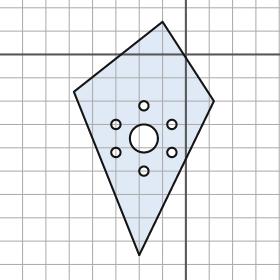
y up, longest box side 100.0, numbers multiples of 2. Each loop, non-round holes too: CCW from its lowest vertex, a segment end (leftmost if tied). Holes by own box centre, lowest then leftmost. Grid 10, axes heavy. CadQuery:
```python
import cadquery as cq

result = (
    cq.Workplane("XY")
    .moveTo(-20.0, -86.0)
    .lineTo(12.0, -20.0)
    .lineTo(-10.0, 14.0)
    .lineTo(-48.0, -16.0)
    .close()
    .moveTo(-18.0, -50.0)
    .circle(2.0)
    .moveTo(-30.0, -42.0)
    .circle(2.0)
    .moveTo(-6.0, -42.0)
    .circle(2.0)
    .moveTo(-18.0, -36.0)
    .circle(6.0)
    .moveTo(-30.0, -30.0)
    .circle(2.0)
    .moveTo(-6.0, -30.0)
    .circle(2.0)
    .moveTo(-18.0, -22.0)
    .circle(2.0)
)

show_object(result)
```